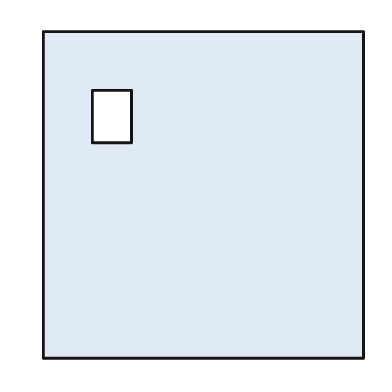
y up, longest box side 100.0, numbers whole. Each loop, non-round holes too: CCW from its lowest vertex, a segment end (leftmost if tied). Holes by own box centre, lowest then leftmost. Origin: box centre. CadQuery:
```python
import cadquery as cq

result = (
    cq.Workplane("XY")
    .moveTo(-49.0, -50.0)
    .lineTo(49.0, -50.0)
    .lineTo(49.0, 50.0)
    .lineTo(-49.0, 50.0)
    .close()
    .moveTo(-34.0, 16.0)
    .lineTo(-22.0, 16.0)
    .lineTo(-22.0, 32.0)
    .lineTo(-34.0, 32.0)
    .close()
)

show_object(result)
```